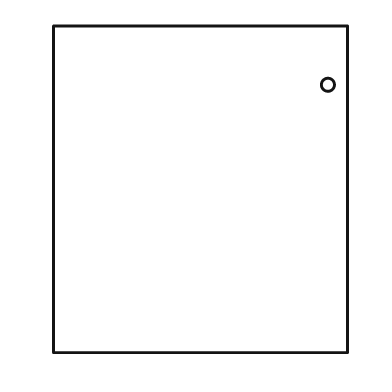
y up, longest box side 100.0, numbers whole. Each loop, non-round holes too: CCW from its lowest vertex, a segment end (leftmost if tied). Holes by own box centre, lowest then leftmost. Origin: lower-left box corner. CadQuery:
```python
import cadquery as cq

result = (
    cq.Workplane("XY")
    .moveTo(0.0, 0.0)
    .lineTo(90.0, 0.0)
    .lineTo(90.0, 100.0)
    .lineTo(0.0, 100.0)
    .close()
    .moveTo(84.0, 82.0)
    .circle(2.0)
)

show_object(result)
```